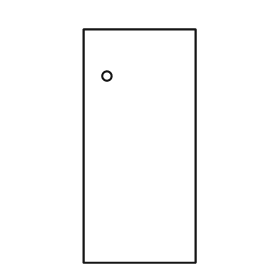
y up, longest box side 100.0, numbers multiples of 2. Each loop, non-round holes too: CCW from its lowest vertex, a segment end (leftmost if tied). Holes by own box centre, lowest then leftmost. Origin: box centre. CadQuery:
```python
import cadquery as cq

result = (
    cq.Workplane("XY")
    .moveTo(-24.0, -50.0)
    .lineTo(24.0, -50.0)
    .lineTo(24.0, 50.0)
    .lineTo(-24.0, 50.0)
    .close()
    .moveTo(-14.0, 30.0)
    .circle(2.0)
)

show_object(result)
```